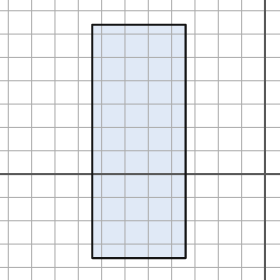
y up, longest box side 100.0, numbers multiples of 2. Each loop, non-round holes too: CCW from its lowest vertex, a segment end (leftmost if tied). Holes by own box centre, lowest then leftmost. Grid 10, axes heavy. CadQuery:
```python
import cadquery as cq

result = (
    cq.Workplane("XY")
    .moveTo(-74.0, -36.0)
    .lineTo(-34.0, -36.0)
    .lineTo(-34.0, 64.0)
    .lineTo(-74.0, 64.0)
    .close()
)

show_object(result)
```